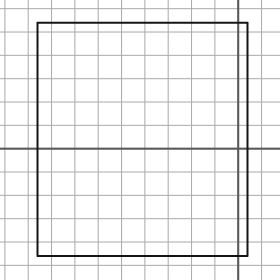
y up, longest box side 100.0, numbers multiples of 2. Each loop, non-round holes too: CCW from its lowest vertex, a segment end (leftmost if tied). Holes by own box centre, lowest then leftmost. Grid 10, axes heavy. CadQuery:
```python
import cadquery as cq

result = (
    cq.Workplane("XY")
    .moveTo(-86.0, -46.0)
    .lineTo(4.0, -46.0)
    .lineTo(4.0, 54.0)
    .lineTo(-86.0, 54.0)
    .close()
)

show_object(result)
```